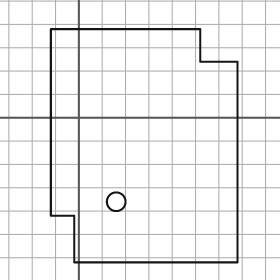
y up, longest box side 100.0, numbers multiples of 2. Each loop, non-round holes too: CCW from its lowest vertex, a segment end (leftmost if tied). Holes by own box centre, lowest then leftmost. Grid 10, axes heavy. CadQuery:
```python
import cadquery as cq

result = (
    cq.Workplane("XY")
    .moveTo(-2.0, -62.0)
    .lineTo(68.0, -62.0)
    .lineTo(68.0, 24.0)
    .lineTo(52.0, 24.0)
    .lineTo(52.0, 38.0)
    .lineTo(-12.0, 38.0)
    .lineTo(-12.0, -42.0)
    .lineTo(-2.0, -42.0)
    .close()
    .moveTo(16.0, -36.0)
    .circle(4.0)
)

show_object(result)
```